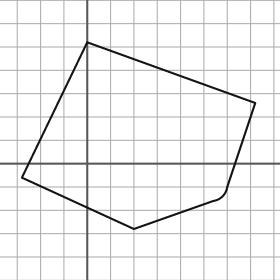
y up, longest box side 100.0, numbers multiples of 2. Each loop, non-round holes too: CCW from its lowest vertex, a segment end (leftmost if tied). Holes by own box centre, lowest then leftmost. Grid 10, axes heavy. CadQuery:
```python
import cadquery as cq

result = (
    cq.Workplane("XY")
    .moveTo(20.0, -28.0)
    .lineTo(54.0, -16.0)
    .threePointArc((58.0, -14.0), (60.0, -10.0))
    .lineTo(72.0, 26.0)
    .lineTo(0.0, 52.0)
    .lineTo(-28.0, -6.0)
    .close()
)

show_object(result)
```